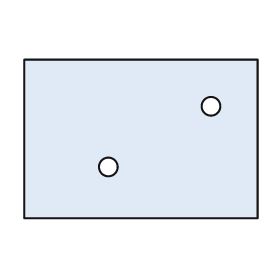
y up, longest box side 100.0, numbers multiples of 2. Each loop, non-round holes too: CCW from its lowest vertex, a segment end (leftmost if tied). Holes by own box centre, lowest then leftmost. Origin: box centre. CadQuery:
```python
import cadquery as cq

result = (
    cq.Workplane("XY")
    .moveTo(-50.0, -34.0)
    .lineTo(50.0, -34.0)
    .lineTo(50.0, 34.0)
    .lineTo(-50.0, 34.0)
    .close()
    .moveTo(-14.0, -12.0)
    .circle(4.0)
    .moveTo(30.0, 14.0)
    .circle(4.0)
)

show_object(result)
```